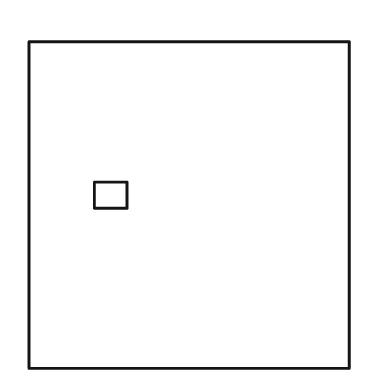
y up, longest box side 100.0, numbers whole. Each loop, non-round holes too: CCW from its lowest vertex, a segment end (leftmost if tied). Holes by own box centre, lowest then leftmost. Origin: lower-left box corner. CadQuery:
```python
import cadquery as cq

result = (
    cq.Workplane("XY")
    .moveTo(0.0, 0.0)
    .lineTo(98.0, 0.0)
    .lineTo(98.0, 100.0)
    .lineTo(0.0, 100.0)
    .close()
    .moveTo(20.0, 49.0)
    .lineTo(30.0, 49.0)
    .lineTo(30.0, 57.0)
    .lineTo(20.0, 57.0)
    .close()
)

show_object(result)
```